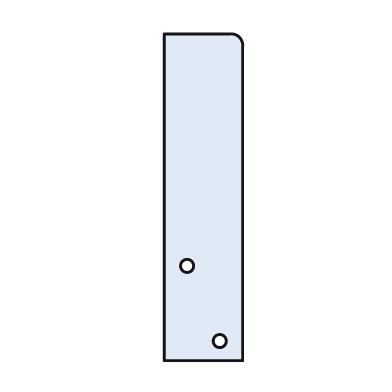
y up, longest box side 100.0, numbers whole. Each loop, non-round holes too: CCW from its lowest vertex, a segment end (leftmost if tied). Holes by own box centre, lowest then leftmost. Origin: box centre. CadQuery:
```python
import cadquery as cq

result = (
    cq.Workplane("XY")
    .moveTo(-12.0, -50.0)
    .lineTo(12.0, -50.0)
    .lineTo(12.0, 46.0)
    .threePointArc((11.0, 49.0), (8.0, 50.0))
    .lineTo(-12.0, 50.0)
    .close()
    .moveTo(5.0, -44.0)
    .circle(2.0)
    .moveTo(-5.0, -21.0)
    .circle(2.0)
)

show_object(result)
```